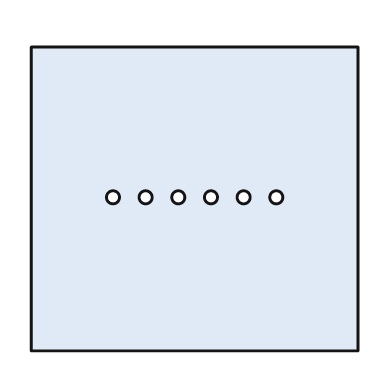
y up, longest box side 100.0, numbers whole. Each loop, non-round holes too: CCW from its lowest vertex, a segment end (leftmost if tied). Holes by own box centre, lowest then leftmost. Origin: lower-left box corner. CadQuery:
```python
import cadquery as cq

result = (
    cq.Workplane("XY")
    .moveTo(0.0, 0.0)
    .lineTo(100.0, 0.0)
    .lineTo(100.0, 93.0)
    .lineTo(0.0, 93.0)
    .close()
    .moveTo(25.0, 47.0)
    .circle(2.0)
    .moveTo(35.0, 47.0)
    .circle(2.0)
    .moveTo(45.0, 47.0)
    .circle(2.0)
    .moveTo(55.0, 47.0)
    .circle(2.0)
    .moveTo(65.0, 47.0)
    .circle(2.0)
    .moveTo(75.0, 47.0)
    .circle(2.0)
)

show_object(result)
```